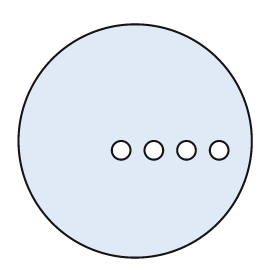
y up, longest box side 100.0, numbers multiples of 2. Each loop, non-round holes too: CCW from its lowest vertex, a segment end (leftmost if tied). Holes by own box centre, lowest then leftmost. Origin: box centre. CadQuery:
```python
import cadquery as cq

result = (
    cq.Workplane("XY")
    .moveTo(0.0, 0.0)
    .circle(50.0)
    .moveTo(-6.0, -4.0)
    .circle(4.0)
    .moveTo(8.0, -4.0)
    .circle(4.0)
    .moveTo(22.0, -4.0)
    .circle(4.0)
    .moveTo(36.0, -4.0)
    .circle(4.0)
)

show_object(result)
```